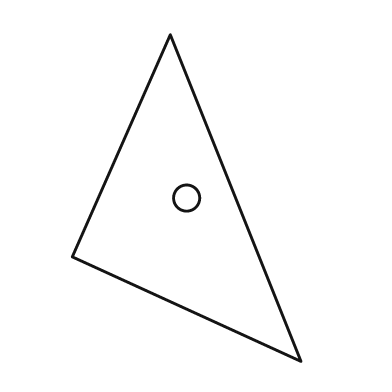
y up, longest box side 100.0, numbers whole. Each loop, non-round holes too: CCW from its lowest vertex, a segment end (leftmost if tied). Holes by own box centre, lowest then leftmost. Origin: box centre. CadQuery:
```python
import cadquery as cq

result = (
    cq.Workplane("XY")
    .moveTo(35.0, -50.0)
    .lineTo(-5.0, 50.0)
    .lineTo(-35.0, -18.0)
    .close()
    .moveTo(0.0, 0.0)
    .circle(4.0)
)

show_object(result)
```